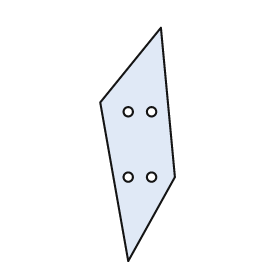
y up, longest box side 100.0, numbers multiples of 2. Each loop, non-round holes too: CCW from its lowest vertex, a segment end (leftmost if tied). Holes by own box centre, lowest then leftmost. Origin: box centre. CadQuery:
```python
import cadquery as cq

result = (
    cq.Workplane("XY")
    .moveTo(-4.0, -50.0)
    .lineTo(16.0, -14.0)
    .lineTo(10.0, 50.0)
    .lineTo(-16.0, 18.0)
    .close()
    .moveTo(-4.0, -14.0)
    .circle(2.0)
    .moveTo(6.0, -14.0)
    .circle(2.0)
    .moveTo(-4.0, 14.0)
    .circle(2.0)
    .moveTo(6.0, 14.0)
    .circle(2.0)
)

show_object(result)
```